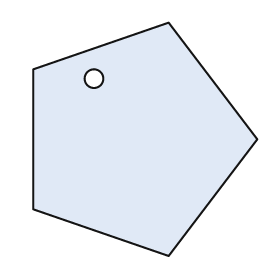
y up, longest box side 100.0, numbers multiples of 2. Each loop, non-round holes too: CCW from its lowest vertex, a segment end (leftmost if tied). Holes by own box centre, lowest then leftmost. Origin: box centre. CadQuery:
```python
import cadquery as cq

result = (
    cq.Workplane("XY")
    .moveTo(10.0, -50.0)
    .lineTo(48.0, 0.0)
    .lineTo(10.0, 50.0)
    .lineTo(-48.0, 30.0)
    .lineTo(-48.0, -30.0)
    .close()
    .moveTo(-22.0, 26.0)
    .circle(4.0)
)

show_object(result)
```